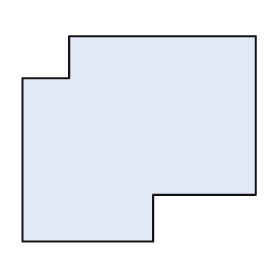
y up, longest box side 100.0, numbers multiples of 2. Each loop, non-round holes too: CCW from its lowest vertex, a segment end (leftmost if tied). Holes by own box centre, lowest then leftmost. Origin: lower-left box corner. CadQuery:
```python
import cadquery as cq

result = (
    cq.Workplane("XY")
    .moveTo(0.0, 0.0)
    .lineTo(56.0, 0.0)
    .lineTo(56.0, 20.0)
    .lineTo(100.0, 20.0)
    .lineTo(100.0, 88.0)
    .lineTo(20.0, 88.0)
    .lineTo(20.0, 70.0)
    .lineTo(0.0, 70.0)
    .close()
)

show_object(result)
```